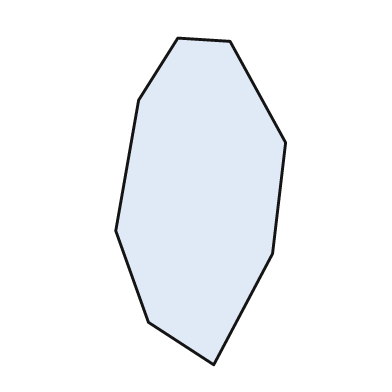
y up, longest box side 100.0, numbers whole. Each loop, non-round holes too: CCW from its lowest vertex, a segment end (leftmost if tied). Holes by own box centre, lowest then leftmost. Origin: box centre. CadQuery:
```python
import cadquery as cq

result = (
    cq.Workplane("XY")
    .moveTo(4.0, -50.0)
    .lineTo(22.0, -16.0)
    .lineTo(26.0, 18.0)
    .lineTo(9.0, 49.0)
    .lineTo(-7.0, 50.0)
    .lineTo(-19.0, 31.0)
    .lineTo(-26.0, -9.0)
    .lineTo(-16.0, -37.0)
    .close()
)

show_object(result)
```